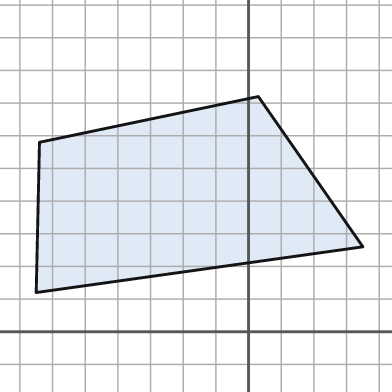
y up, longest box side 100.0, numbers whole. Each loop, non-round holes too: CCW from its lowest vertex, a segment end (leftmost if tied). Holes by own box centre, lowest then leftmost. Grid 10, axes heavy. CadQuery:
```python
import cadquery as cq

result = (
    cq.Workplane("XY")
    .moveTo(-65.0, 12.0)
    .lineTo(35.0, 26.0)
    .lineTo(3.0, 72.0)
    .lineTo(-64.0, 58.0)
    .close()
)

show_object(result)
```